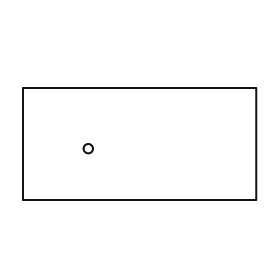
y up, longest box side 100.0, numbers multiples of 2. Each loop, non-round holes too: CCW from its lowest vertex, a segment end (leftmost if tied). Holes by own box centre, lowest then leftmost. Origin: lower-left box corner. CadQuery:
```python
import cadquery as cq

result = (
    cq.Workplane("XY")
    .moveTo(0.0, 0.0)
    .lineTo(100.0, 0.0)
    .lineTo(100.0, 48.0)
    .lineTo(0.0, 48.0)
    .close()
    .moveTo(28.0, 22.0)
    .circle(2.0)
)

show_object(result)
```